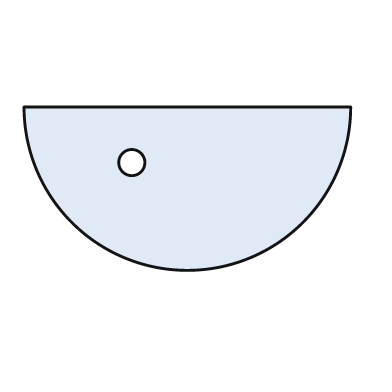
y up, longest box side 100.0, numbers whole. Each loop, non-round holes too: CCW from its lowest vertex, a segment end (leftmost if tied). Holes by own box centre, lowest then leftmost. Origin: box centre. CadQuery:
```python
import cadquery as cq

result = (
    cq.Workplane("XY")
    .moveTo(-50.0, 25.0)
    .threePointArc((0.0, -25.0), (50.0, 25.0))
    .close()
    .moveTo(-17.0, 8.0)
    .circle(4.0)
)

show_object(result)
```